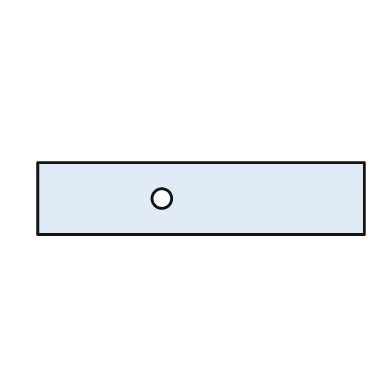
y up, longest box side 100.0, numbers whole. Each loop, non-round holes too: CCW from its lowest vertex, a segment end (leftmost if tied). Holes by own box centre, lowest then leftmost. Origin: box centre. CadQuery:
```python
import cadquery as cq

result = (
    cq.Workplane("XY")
    .moveTo(-50.0, -11.0)
    .lineTo(50.0, -11.0)
    .lineTo(50.0, 11.0)
    .lineTo(-50.0, 11.0)
    .close()
    .moveTo(-12.0, 0.0)
    .circle(3.0)
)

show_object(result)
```